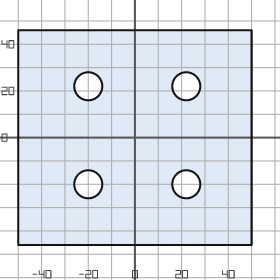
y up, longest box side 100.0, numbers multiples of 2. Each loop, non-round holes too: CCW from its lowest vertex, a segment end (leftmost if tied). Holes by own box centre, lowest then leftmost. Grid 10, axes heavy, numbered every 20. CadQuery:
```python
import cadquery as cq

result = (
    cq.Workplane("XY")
    .moveTo(-50.0, -46.0)
    .lineTo(50.0, -46.0)
    .lineTo(50.0, 46.0)
    .lineTo(-50.0, 46.0)
    .close()
    .moveTo(-20.0, -20.0)
    .circle(6.0)
    .moveTo(22.0, -20.0)
    .circle(6.0)
    .moveTo(-20.0, 22.0)
    .circle(6.0)
    .moveTo(22.0, 22.0)
    .circle(6.0)
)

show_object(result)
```